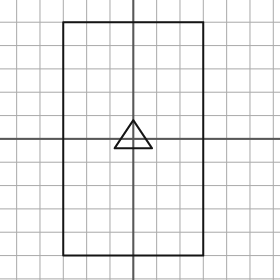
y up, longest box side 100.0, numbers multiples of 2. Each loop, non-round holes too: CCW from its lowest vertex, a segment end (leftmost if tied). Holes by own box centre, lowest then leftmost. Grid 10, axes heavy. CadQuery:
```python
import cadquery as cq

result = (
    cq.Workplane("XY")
    .moveTo(-30.0, -50.0)
    .lineTo(30.0, -50.0)
    .lineTo(30.0, 50.0)
    .lineTo(-30.0, 50.0)
    .close()
    .moveTo(-8.0, -4.0)
    .lineTo(8.0, -4.0)
    .lineTo(0.0, 8.0)
    .close()
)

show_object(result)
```